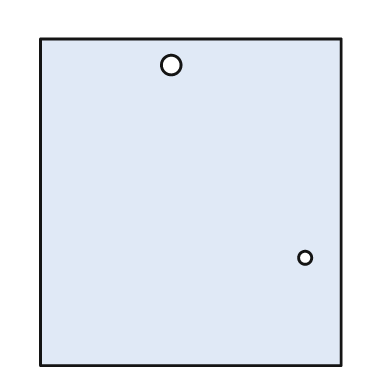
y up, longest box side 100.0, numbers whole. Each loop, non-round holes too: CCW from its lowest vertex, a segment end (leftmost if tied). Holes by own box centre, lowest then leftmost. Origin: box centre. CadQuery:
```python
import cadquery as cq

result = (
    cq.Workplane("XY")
    .moveTo(-46.0, -50.0)
    .lineTo(46.0, -50.0)
    .lineTo(46.0, 50.0)
    .lineTo(-46.0, 50.0)
    .close()
    .moveTo(35.0, -17.0)
    .circle(2.0)
    .moveTo(-6.0, 42.0)
    .circle(3.0)
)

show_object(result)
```